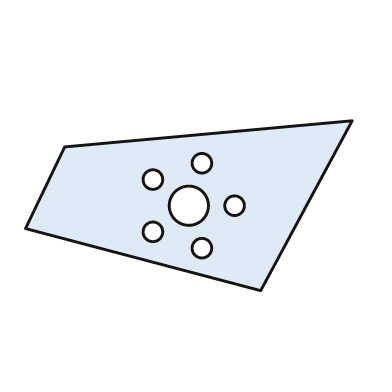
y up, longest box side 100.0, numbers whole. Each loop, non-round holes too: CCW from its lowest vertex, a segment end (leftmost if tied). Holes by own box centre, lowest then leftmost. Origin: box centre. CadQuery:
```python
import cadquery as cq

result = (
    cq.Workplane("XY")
    .moveTo(22.0, -26.0)
    .lineTo(50.0, 26.0)
    .lineTo(-38.0, 18.0)
    .lineTo(-50.0, -7.0)
    .close()
    .moveTo(4.0, -13.0)
    .circle(3.0)
    .moveTo(-11.0, -8.0)
    .circle(3.0)
    .moveTo(0.0, 0.0)
    .circle(6.0)
    .moveTo(14.0, 0.0)
    .circle(3.0)
    .moveTo(-11.0, 8.0)
    .circle(3.0)
    .moveTo(4.0, 13.0)
    .circle(3.0)
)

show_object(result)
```